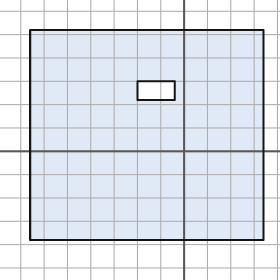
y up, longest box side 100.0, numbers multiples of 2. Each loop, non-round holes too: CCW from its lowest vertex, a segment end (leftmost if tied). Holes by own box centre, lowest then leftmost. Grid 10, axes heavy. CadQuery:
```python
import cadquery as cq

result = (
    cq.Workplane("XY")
    .moveTo(-66.0, -38.0)
    .lineTo(34.0, -38.0)
    .lineTo(34.0, 52.0)
    .lineTo(-66.0, 52.0)
    .close()
    .moveTo(-20.0, 22.0)
    .lineTo(-4.0, 22.0)
    .lineTo(-4.0, 30.0)
    .lineTo(-20.0, 30.0)
    .close()
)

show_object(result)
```